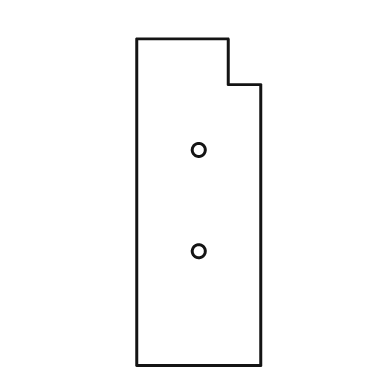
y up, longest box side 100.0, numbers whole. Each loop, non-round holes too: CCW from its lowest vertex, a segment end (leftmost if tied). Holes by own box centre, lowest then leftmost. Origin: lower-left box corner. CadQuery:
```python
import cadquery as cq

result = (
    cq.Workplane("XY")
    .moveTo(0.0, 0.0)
    .lineTo(38.0, 0.0)
    .lineTo(38.0, 86.0)
    .lineTo(28.0, 86.0)
    .lineTo(28.0, 100.0)
    .lineTo(0.0, 100.0)
    .close()
    .moveTo(19.0, 35.0)
    .circle(2.0)
    .moveTo(19.0, 66.0)
    .circle(2.0)
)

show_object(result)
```